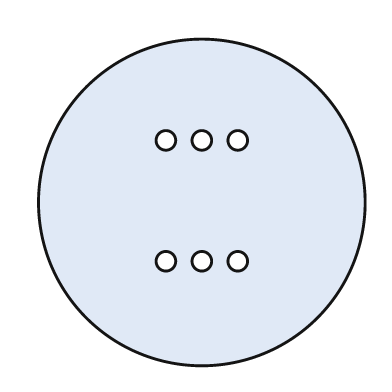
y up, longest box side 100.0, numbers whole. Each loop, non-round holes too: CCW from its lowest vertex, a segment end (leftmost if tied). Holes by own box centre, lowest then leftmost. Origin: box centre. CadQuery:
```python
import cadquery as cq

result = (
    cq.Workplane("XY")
    .moveTo(0.0, 0.0)
    .circle(50.0)
    .moveTo(-11.0, -18.0)
    .circle(3.0)
    .moveTo(0.0, -18.0)
    .circle(3.0)
    .moveTo(11.0, -18.0)
    .circle(3.0)
    .moveTo(-11.0, 19.0)
    .circle(3.0)
    .moveTo(0.0, 19.0)
    .circle(3.0)
    .moveTo(11.0, 19.0)
    .circle(3.0)
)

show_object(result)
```